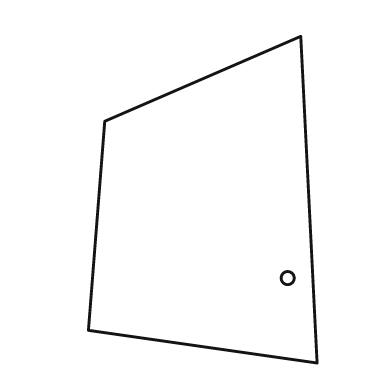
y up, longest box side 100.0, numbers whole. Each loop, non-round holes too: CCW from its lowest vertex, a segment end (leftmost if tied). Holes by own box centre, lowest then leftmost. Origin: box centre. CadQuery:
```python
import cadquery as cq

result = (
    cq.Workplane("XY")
    .moveTo(35.0, -50.0)
    .lineTo(30.0, 50.0)
    .lineTo(-30.0, 24.0)
    .lineTo(-35.0, -40.0)
    .close()
    .moveTo(26.0, -24.0)
    .circle(2.0)
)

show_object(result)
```